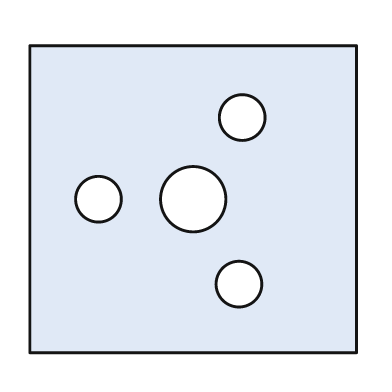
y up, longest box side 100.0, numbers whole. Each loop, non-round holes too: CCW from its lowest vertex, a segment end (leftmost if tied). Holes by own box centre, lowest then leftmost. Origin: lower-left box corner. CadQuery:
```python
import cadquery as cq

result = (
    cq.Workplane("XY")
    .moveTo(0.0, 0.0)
    .lineTo(100.0, 0.0)
    .lineTo(100.0, 94.0)
    .lineTo(0.0, 94.0)
    .close()
    .moveTo(64.0, 21.0)
    .circle(7.0)
    .moveTo(21.0, 47.0)
    .circle(7.0)
    .moveTo(50.0, 47.0)
    .circle(10.0)
    .moveTo(65.0, 72.0)
    .circle(7.0)
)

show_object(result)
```